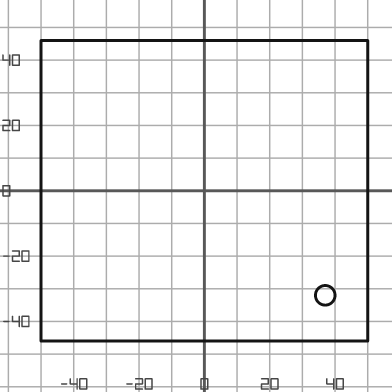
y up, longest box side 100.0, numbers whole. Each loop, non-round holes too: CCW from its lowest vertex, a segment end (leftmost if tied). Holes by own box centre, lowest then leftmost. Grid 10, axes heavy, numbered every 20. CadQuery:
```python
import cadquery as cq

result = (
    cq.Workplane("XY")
    .moveTo(-50.0, -46.0)
    .lineTo(50.0, -46.0)
    .lineTo(50.0, 46.0)
    .lineTo(-50.0, 46.0)
    .close()
    .moveTo(37.0, -32.0)
    .circle(3.0)
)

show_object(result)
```